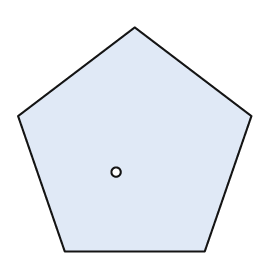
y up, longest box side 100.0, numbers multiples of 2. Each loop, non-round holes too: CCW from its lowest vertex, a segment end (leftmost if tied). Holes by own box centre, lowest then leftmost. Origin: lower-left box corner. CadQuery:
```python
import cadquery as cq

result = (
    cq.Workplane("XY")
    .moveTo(20.0, 0.0)
    .lineTo(80.0, 0.0)
    .lineTo(100.0, 58.0)
    .lineTo(50.0, 96.0)
    .lineTo(0.0, 58.0)
    .close()
    .moveTo(42.0, 34.0)
    .circle(2.0)
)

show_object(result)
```